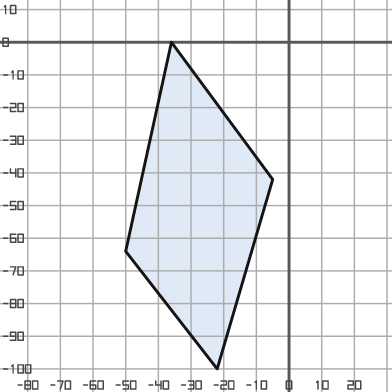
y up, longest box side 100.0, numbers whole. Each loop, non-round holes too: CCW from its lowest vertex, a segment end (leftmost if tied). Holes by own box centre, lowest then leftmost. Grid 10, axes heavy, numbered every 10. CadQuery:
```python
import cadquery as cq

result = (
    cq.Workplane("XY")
    .moveTo(-22.0, -100.0)
    .lineTo(-5.0, -42.0)
    .lineTo(-36.0, 0.0)
    .lineTo(-50.0, -64.0)
    .close()
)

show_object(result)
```